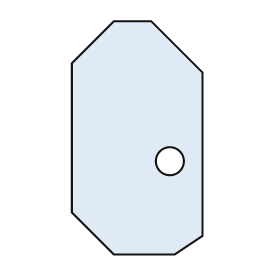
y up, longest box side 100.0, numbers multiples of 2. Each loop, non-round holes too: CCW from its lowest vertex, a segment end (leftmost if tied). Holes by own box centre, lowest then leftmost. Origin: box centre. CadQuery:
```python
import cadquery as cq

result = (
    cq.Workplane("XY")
    .moveTo(-10.0, -50.0)
    .lineTo(16.0, -50.0)
    .lineTo(28.0, -42.0)
    .lineTo(28.0, 28.0)
    .lineTo(6.0, 50.0)
    .lineTo(-10.0, 50.0)
    .lineTo(-28.0, 32.0)
    .lineTo(-28.0, -32.0)
    .close()
    .moveTo(14.0, -10.0)
    .circle(6.0)
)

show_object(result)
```